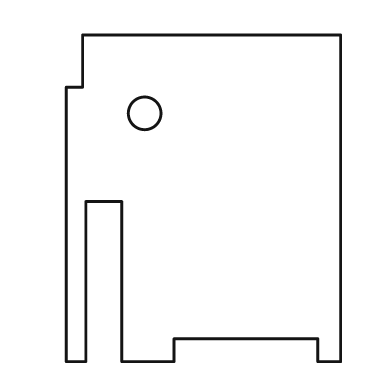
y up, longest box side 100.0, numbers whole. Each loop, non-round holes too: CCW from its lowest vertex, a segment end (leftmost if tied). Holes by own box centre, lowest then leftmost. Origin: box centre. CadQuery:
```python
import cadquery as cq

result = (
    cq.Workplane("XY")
    .moveTo(-42.0, -50.0)
    .lineTo(-36.0, -50.0)
    .lineTo(-36.0, -1.0)
    .lineTo(-25.0, -1.0)
    .lineTo(-25.0, -50.0)
    .lineTo(-9.0, -50.0)
    .lineTo(-9.0, -43.0)
    .lineTo(35.0, -43.0)
    .lineTo(35.0, -50.0)
    .lineTo(42.0, -50.0)
    .lineTo(42.0, 50.0)
    .lineTo(-37.0, 50.0)
    .lineTo(-37.0, 34.0)
    .lineTo(-42.0, 34.0)
    .close()
    .moveTo(-18.0, 26.0)
    .circle(5.0)
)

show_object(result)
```